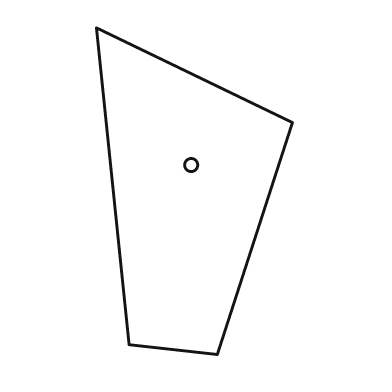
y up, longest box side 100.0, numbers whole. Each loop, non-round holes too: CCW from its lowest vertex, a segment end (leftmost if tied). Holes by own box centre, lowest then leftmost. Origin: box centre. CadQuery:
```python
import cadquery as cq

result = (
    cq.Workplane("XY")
    .moveTo(7.0, -50.0)
    .lineTo(30.0, 21.0)
    .lineTo(-30.0, 50.0)
    .lineTo(-20.0, -47.0)
    .close()
    .moveTo(-1.0, 8.0)
    .circle(2.0)
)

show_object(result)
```